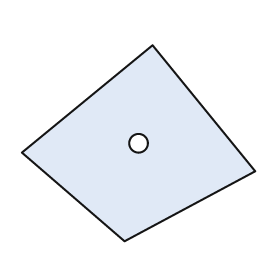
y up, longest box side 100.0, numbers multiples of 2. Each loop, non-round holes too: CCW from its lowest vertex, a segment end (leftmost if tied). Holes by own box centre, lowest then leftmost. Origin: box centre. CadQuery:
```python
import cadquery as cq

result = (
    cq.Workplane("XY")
    .moveTo(-6.0, -42.0)
    .lineTo(50.0, -12.0)
    .lineTo(6.0, 42.0)
    .lineTo(-50.0, -4.0)
    .close()
    .moveTo(0.0, 0.0)
    .circle(4.0)
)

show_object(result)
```